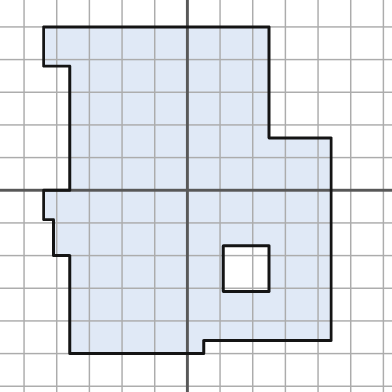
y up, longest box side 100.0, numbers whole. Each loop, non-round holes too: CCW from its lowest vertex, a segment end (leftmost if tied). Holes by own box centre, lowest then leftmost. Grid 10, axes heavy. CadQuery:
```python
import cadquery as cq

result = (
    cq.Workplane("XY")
    .moveTo(-36.0, -50.0)
    .lineTo(5.0, -50.0)
    .lineTo(5.0, -46.0)
    .lineTo(44.0, -46.0)
    .lineTo(44.0, 16.0)
    .lineTo(25.0, 16.0)
    .lineTo(25.0, 50.0)
    .lineTo(-44.0, 50.0)
    .lineTo(-44.0, 38.0)
    .lineTo(-36.0, 38.0)
    .lineTo(-36.0, 0.0)
    .lineTo(-44.0, 0.0)
    .lineTo(-44.0, -9.0)
    .lineTo(-41.0, -9.0)
    .lineTo(-41.0, -20.0)
    .lineTo(-36.0, -20.0)
    .close()
    .moveTo(11.0, -31.0)
    .lineTo(25.0, -31.0)
    .lineTo(25.0, -17.0)
    .lineTo(11.0, -17.0)
    .close()
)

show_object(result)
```